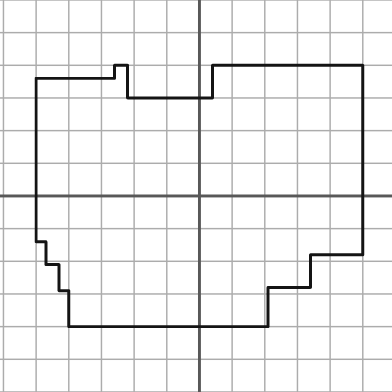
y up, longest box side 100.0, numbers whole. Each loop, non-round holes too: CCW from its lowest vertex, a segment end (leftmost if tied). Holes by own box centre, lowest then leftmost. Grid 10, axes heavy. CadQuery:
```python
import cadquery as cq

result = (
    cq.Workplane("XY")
    .moveTo(-40.0, -40.0)
    .lineTo(21.0, -40.0)
    .lineTo(21.0, -28.0)
    .lineTo(34.0, -28.0)
    .lineTo(34.0, -18.0)
    .lineTo(50.0, -18.0)
    .lineTo(50.0, 40.0)
    .lineTo(4.0, 40.0)
    .lineTo(4.0, 30.0)
    .lineTo(-22.0, 30.0)
    .lineTo(-22.0, 40.0)
    .lineTo(-26.0, 40.0)
    .lineTo(-26.0, 36.0)
    .lineTo(-50.0, 36.0)
    .lineTo(-50.0, -14.0)
    .lineTo(-47.0, -14.0)
    .lineTo(-47.0, -21.0)
    .lineTo(-43.0, -21.0)
    .lineTo(-43.0, -29.0)
    .lineTo(-40.0, -29.0)
    .close()
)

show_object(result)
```